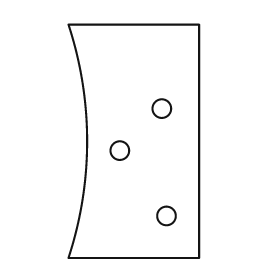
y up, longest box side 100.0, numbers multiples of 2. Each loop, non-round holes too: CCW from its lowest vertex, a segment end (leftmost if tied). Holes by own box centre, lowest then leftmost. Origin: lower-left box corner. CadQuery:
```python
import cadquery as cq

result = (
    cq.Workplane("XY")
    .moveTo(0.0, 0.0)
    .lineTo(56.0, 0.0)
    .lineTo(56.0, 100.0)
    .lineTo(0.0, 100.0)
    .threePointArc((8.0, 50.0), (0.0, 0.0))
    .close()
    .moveTo(42.0, 18.0)
    .circle(4.0)
    .moveTo(22.0, 46.0)
    .circle(4.0)
    .moveTo(40.0, 64.0)
    .circle(4.0)
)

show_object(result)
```